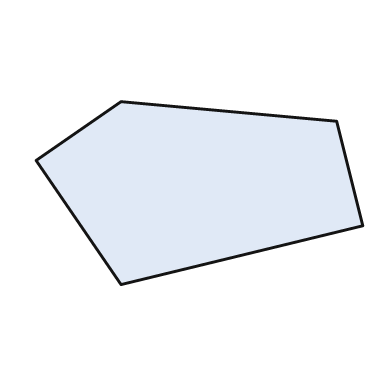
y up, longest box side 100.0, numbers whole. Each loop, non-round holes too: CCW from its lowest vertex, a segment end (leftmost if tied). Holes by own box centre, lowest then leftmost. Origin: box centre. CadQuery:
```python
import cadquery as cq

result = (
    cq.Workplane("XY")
    .moveTo(-24.0, -28.0)
    .lineTo(50.0, -10.0)
    .lineTo(42.0, 22.0)
    .lineTo(-24.0, 28.0)
    .lineTo(-50.0, 10.0)
    .close()
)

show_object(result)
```